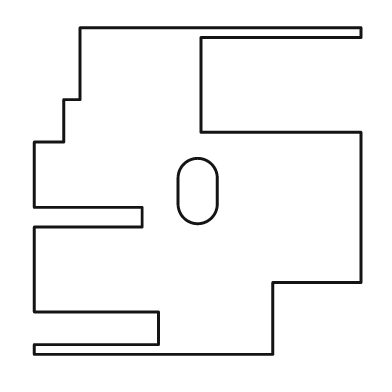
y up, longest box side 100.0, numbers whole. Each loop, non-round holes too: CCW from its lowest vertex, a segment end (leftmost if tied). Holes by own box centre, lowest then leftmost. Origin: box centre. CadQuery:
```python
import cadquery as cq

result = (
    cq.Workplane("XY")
    .moveTo(-50.0, -50.0)
    .lineTo(23.0, -50.0)
    .lineTo(23.0, -28.0)
    .lineTo(50.0, -28.0)
    .lineTo(50.0, 18.0)
    .lineTo(1.0, 18.0)
    .lineTo(1.0, 47.0)
    .lineTo(50.0, 47.0)
    .lineTo(50.0, 50.0)
    .lineTo(-36.0, 50.0)
    .lineTo(-36.0, 28.0)
    .lineTo(-41.0, 28.0)
    .lineTo(-41.0, 15.0)
    .lineTo(-50.0, 15.0)
    .lineTo(-50.0, -5.0)
    .lineTo(-17.0, -5.0)
    .lineTo(-17.0, -11.0)
    .lineTo(-50.0, -11.0)
    .lineTo(-50.0, -37.0)
    .lineTo(-12.0, -37.0)
    .lineTo(-12.0, -47.0)
    .lineTo(-50.0, -47.0)
    .close()
    .moveTo(-6.0, -4.0)
    .threePointArc((0.0, -10.0), (6.0, -4.0))
    .lineTo(6.0, 4.0)
    .threePointArc((0.0, 10.0), (-6.0, 4.0))
    .close()
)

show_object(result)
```